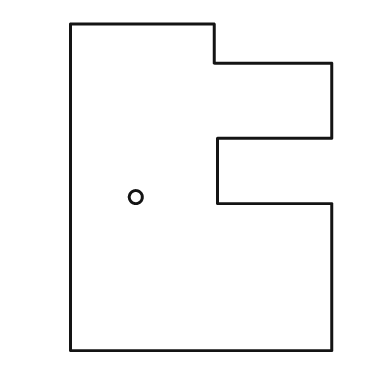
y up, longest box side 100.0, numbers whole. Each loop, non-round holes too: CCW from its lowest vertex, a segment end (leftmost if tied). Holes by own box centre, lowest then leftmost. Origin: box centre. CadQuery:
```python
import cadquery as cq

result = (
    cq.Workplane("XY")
    .moveTo(-40.0, -50.0)
    .lineTo(40.0, -50.0)
    .lineTo(40.0, -5.0)
    .lineTo(5.0, -5.0)
    .lineTo(5.0, 15.0)
    .lineTo(40.0, 15.0)
    .lineTo(40.0, 38.0)
    .lineTo(4.0, 38.0)
    .lineTo(4.0, 50.0)
    .lineTo(-40.0, 50.0)
    .close()
    .moveTo(-20.0, -3.0)
    .circle(2.0)
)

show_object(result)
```